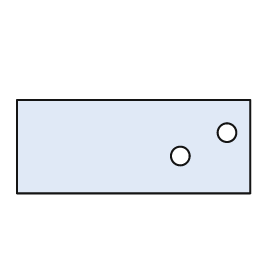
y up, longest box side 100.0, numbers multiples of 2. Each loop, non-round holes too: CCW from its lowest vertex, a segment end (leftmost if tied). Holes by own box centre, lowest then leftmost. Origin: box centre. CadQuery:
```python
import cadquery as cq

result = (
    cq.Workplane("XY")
    .moveTo(-50.0, -20.0)
    .lineTo(50.0, -20.0)
    .lineTo(50.0, 20.0)
    .lineTo(-50.0, 20.0)
    .close()
    .moveTo(20.0, -4.0)
    .circle(4.0)
    .moveTo(40.0, 6.0)
    .circle(4.0)
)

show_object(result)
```